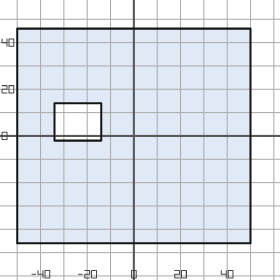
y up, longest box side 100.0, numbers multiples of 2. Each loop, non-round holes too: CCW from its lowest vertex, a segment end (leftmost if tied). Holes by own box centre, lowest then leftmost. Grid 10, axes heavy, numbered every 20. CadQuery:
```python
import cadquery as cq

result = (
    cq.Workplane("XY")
    .moveTo(-50.0, -46.0)
    .lineTo(50.0, -46.0)
    .lineTo(50.0, 46.0)
    .lineTo(-50.0, 46.0)
    .close()
    .moveTo(-34.0, -2.0)
    .lineTo(-14.0, -2.0)
    .lineTo(-14.0, 14.0)
    .lineTo(-34.0, 14.0)
    .close()
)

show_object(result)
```